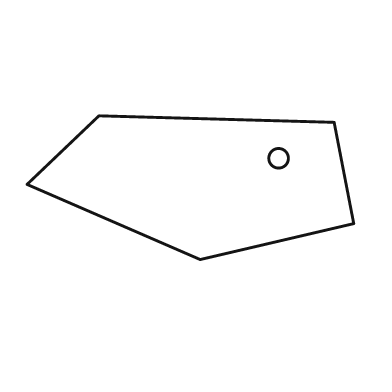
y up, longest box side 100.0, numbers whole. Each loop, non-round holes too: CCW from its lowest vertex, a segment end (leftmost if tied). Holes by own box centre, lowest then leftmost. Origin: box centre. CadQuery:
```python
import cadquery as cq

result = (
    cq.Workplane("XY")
    .moveTo(3.0, -22.0)
    .lineTo(50.0, -11.0)
    .lineTo(44.0, 20.0)
    .lineTo(-28.0, 22.0)
    .lineTo(-50.0, 1.0)
    .close()
    .moveTo(27.0, 9.0)
    .circle(3.0)
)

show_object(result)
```